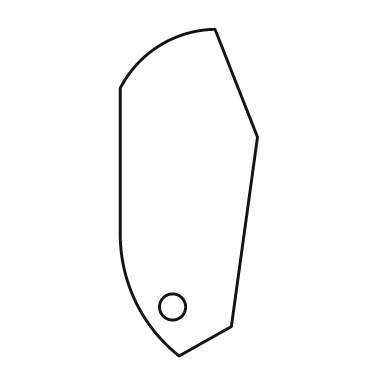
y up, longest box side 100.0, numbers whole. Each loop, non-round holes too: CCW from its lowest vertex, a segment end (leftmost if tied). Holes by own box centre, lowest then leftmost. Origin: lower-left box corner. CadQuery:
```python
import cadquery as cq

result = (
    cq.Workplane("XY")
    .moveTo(18.0, 0.0)
    .lineTo(34.0, 9.0)
    .lineTo(42.0, 67.0)
    .lineTo(29.0, 100.0)
    .threePointArc((12.0, 95.0), (0.0, 82.0))
    .lineTo(0.0, 36.0)
    .threePointArc((5.0, 16.0), (18.0, 0.0))
    .close()
    .moveTo(16.0, 15.0)
    .circle(4.0)
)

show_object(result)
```